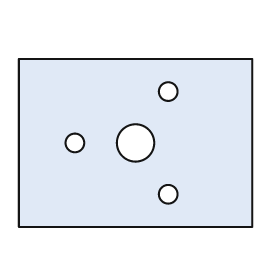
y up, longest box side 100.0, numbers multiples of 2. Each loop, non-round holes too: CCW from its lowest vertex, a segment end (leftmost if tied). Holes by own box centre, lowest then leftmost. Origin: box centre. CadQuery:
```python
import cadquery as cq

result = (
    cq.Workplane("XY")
    .moveTo(-50.0, -36.0)
    .lineTo(50.0, -36.0)
    .lineTo(50.0, 36.0)
    .lineTo(-50.0, 36.0)
    .close()
    .moveTo(14.0, -22.0)
    .circle(4.0)
    .moveTo(-26.0, 0.0)
    .circle(4.0)
    .moveTo(0.0, 0.0)
    .circle(8.0)
    .moveTo(14.0, 22.0)
    .circle(4.0)
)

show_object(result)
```